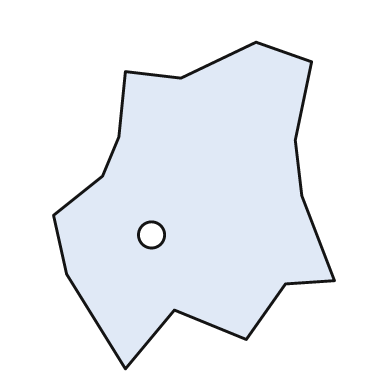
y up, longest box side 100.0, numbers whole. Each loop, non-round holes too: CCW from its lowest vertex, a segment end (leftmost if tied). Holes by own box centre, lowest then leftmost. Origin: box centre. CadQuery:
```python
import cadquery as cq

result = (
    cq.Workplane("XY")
    .moveTo(-21.0, -50.0)
    .lineTo(-6.0, -32.0)
    .lineTo(16.0, -41.0)
    .lineTo(28.0, -24.0)
    .lineTo(43.0, -23.0)
    .lineTo(33.0, 3.0)
    .lineTo(31.0, 20.0)
    .lineTo(36.0, 44.0)
    .lineTo(19.0, 50.0)
    .lineTo(-4.0, 39.0)
    .lineTo(-21.0, 41.0)
    .lineTo(-23.0, 21.0)
    .lineTo(-28.0, 9.0)
    .lineTo(-43.0, -3.0)
    .lineTo(-39.0, -21.0)
    .close()
    .moveTo(-13.0, -9.0)
    .circle(4.0)
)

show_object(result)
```